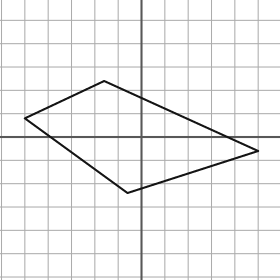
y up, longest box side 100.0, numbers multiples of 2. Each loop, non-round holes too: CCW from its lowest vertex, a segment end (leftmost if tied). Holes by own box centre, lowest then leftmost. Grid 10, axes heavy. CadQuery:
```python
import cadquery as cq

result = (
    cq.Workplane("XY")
    .moveTo(-6.0, -24.0)
    .lineTo(50.0, -6.0)
    .lineTo(-16.0, 24.0)
    .lineTo(-50.0, 8.0)
    .close()
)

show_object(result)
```